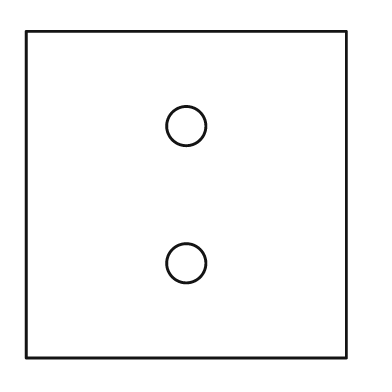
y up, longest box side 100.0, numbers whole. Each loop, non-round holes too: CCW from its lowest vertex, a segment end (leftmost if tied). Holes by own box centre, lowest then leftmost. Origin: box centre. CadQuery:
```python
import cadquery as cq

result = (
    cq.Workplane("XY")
    .moveTo(-49.0, -50.0)
    .lineTo(49.0, -50.0)
    .lineTo(49.0, 50.0)
    .lineTo(-49.0, 50.0)
    .close()
    .moveTo(0.0, -21.0)
    .circle(6.0)
    .moveTo(0.0, 21.0)
    .circle(6.0)
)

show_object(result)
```